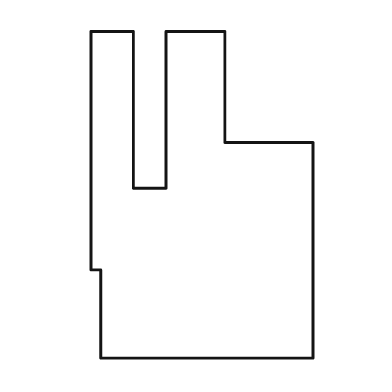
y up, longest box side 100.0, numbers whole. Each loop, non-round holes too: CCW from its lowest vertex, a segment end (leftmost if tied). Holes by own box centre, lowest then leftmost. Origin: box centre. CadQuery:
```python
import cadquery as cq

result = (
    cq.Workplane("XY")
    .moveTo(-31.0, -50.0)
    .lineTo(34.0, -50.0)
    .lineTo(34.0, 16.0)
    .lineTo(7.0, 16.0)
    .lineTo(7.0, 50.0)
    .lineTo(-11.0, 50.0)
    .lineTo(-11.0, 2.0)
    .lineTo(-21.0, 2.0)
    .lineTo(-21.0, 50.0)
    .lineTo(-34.0, 50.0)
    .lineTo(-34.0, -23.0)
    .lineTo(-31.0, -23.0)
    .close()
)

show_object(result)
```